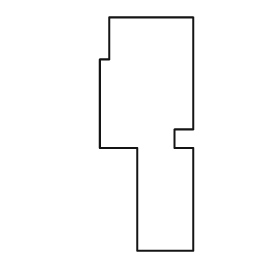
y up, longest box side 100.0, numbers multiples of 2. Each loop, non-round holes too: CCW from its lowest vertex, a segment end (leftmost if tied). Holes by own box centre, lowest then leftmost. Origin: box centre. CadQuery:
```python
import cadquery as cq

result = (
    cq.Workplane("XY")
    .moveTo(-4.0, -50.0)
    .lineTo(20.0, -50.0)
    .lineTo(20.0, -6.0)
    .lineTo(12.0, -6.0)
    .lineTo(12.0, 2.0)
    .lineTo(20.0, 2.0)
    .lineTo(20.0, 50.0)
    .lineTo(-16.0, 50.0)
    .lineTo(-16.0, 32.0)
    .lineTo(-20.0, 32.0)
    .lineTo(-20.0, -6.0)
    .lineTo(-4.0, -6.0)
    .close()
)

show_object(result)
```